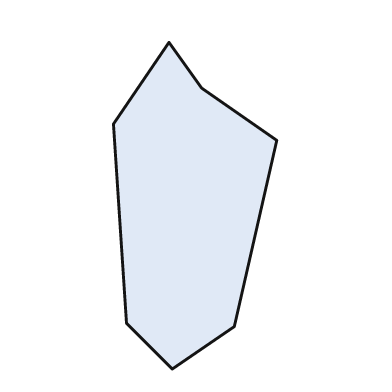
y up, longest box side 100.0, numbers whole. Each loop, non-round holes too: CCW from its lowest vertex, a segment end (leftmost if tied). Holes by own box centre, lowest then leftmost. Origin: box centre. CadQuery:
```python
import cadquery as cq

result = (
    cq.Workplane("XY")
    .moveTo(-7.0, -50.0)
    .lineTo(12.0, -37.0)
    .lineTo(25.0, 20.0)
    .lineTo(2.0, 36.0)
    .lineTo(-8.0, 50.0)
    .lineTo(-25.0, 25.0)
    .lineTo(-21.0, -36.0)
    .close()
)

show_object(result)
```